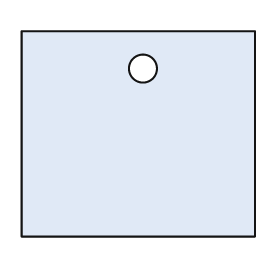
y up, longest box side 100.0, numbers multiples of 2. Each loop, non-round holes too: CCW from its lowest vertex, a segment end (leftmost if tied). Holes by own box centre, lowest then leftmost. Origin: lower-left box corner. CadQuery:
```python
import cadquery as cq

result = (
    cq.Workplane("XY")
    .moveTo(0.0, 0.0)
    .lineTo(100.0, 0.0)
    .lineTo(100.0, 88.0)
    .lineTo(0.0, 88.0)
    .close()
    .moveTo(52.0, 72.0)
    .circle(6.0)
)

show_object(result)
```